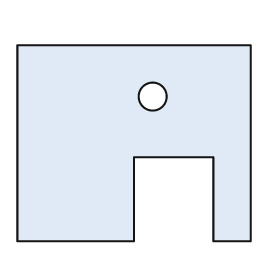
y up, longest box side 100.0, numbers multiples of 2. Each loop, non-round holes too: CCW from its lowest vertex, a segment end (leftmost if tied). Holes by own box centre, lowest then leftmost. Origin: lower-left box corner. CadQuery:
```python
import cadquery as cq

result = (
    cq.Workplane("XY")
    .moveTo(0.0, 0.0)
    .lineTo(50.0, 0.0)
    .lineTo(50.0, 36.0)
    .lineTo(84.0, 36.0)
    .lineTo(84.0, 0.0)
    .lineTo(100.0, 0.0)
    .lineTo(100.0, 84.0)
    .lineTo(0.0, 84.0)
    .close()
    .moveTo(58.0, 62.0)
    .circle(6.0)
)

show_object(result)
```